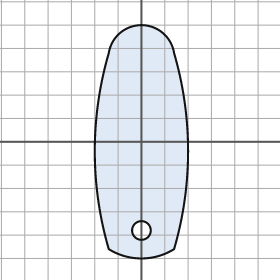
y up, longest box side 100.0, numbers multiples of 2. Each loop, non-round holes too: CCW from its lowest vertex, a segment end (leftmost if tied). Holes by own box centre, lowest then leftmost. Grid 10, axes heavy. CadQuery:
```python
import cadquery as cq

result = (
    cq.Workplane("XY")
    .moveTo(-14.0, -46.0)
    .threePointArc((0.0, -50.0), (14.0, -46.0))
    .threePointArc((20.0, -4.0), (14.0, 38.0))
    .threePointArc((0.0, 50.0), (-14.0, 38.0))
    .threePointArc((-20.0, -4.0), (-14.0, -46.0))
    .close()
    .moveTo(0.0, -38.0)
    .circle(4.0)
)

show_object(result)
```